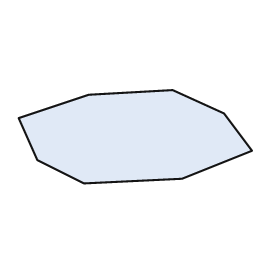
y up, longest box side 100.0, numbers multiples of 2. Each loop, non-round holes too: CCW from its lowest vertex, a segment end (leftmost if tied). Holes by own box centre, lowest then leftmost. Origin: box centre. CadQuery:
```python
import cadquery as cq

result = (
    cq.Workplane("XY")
    .moveTo(-22.0, -20.0)
    .lineTo(20.0, -18.0)
    .lineTo(50.0, -6.0)
    .lineTo(38.0, 10.0)
    .lineTo(16.0, 20.0)
    .lineTo(-20.0, 18.0)
    .lineTo(-50.0, 8.0)
    .lineTo(-42.0, -10.0)
    .close()
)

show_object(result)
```